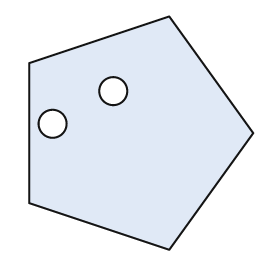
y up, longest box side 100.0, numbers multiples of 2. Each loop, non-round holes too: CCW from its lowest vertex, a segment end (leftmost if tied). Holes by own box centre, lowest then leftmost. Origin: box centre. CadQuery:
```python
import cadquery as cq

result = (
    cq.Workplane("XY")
    .moveTo(12.0, -50.0)
    .lineTo(48.0, 0.0)
    .lineTo(12.0, 50.0)
    .lineTo(-48.0, 30.0)
    .lineTo(-48.0, -30.0)
    .close()
    .moveTo(-38.0, 4.0)
    .circle(6.0)
    .moveTo(-12.0, 18.0)
    .circle(6.0)
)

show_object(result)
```